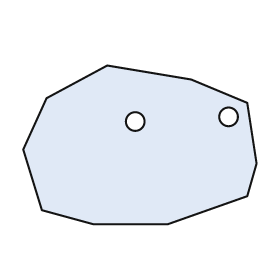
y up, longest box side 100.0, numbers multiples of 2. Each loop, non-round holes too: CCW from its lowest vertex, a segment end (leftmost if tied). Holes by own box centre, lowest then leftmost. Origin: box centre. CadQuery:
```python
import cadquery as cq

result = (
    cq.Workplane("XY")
    .moveTo(-20.0, -34.0)
    .lineTo(12.0, -34.0)
    .lineTo(46.0, -22.0)
    .lineTo(50.0, -8.0)
    .lineTo(46.0, 18.0)
    .lineTo(22.0, 28.0)
    .lineTo(-14.0, 34.0)
    .lineTo(-40.0, 20.0)
    .lineTo(-50.0, -2.0)
    .lineTo(-42.0, -28.0)
    .close()
    .moveTo(-2.0, 10.0)
    .circle(4.0)
    .moveTo(38.0, 12.0)
    .circle(4.0)
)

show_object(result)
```